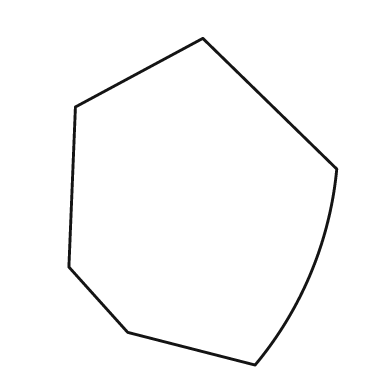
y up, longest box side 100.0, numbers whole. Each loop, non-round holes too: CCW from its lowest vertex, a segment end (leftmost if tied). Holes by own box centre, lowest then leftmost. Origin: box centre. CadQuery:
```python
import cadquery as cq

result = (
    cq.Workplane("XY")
    .moveTo(16.0, -50.0)
    .threePointArc((33.0, -22.0), (41.0, 10.0))
    .lineTo(0.0, 50.0)
    .lineTo(-39.0, 29.0)
    .lineTo(-41.0, -20.0)
    .lineTo(-23.0, -40.0)
    .close()
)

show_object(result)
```